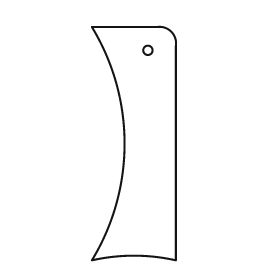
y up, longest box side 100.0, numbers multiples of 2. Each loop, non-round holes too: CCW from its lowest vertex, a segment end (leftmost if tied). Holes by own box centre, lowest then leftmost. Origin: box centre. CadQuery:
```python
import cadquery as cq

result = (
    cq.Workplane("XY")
    .moveTo(-18.0, -50.0)
    .threePointArc((0.0, -48.0), (18.0, -50.0))
    .lineTo(18.0, 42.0)
    .threePointArc((16.0, 48.0), (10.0, 50.0))
    .lineTo(-18.0, 50.0)
    .threePointArc((-4.0, 0.0), (-18.0, -50.0))
    .close()
    .moveTo(6.0, 40.0)
    .circle(2.0)
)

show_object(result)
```